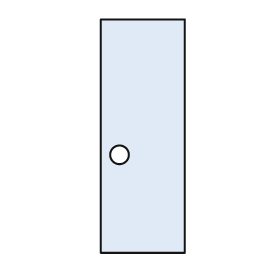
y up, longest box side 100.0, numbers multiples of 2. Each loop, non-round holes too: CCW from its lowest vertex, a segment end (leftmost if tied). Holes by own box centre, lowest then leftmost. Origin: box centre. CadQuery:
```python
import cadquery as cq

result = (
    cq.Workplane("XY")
    .moveTo(-18.0, -50.0)
    .lineTo(18.0, -50.0)
    .lineTo(18.0, 50.0)
    .lineTo(-18.0, 50.0)
    .close()
    .moveTo(-10.0, -8.0)
    .circle(4.0)
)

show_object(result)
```